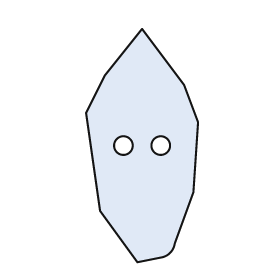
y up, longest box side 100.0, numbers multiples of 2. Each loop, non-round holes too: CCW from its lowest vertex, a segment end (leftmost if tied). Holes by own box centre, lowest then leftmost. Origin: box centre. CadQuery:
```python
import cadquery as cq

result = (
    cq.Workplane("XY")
    .moveTo(-2.0, -50.0)
    .lineTo(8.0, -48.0)
    .threePointArc((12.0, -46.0), (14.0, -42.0))
    .lineTo(22.0, -20.0)
    .lineTo(24.0, 10.0)
    .lineTo(18.0, 26.0)
    .lineTo(0.0, 50.0)
    .lineTo(-16.0, 30.0)
    .lineTo(-24.0, 14.0)
    .lineTo(-18.0, -28.0)
    .close()
    .moveTo(-8.0, 0.0)
    .circle(4.0)
    .moveTo(8.0, 0.0)
    .circle(4.0)
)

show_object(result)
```